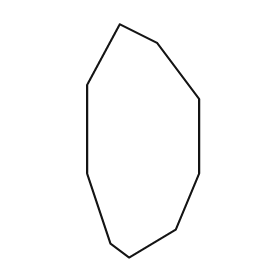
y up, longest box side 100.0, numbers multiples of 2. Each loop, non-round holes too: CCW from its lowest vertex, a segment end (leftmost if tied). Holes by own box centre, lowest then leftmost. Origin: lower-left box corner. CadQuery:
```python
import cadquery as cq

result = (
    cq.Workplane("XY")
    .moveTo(18.0, 0.0)
    .lineTo(38.0, 12.0)
    .lineTo(48.0, 36.0)
    .lineTo(48.0, 68.0)
    .lineTo(30.0, 92.0)
    .lineTo(14.0, 100.0)
    .lineTo(0.0, 74.0)
    .lineTo(0.0, 36.0)
    .lineTo(10.0, 6.0)
    .close()
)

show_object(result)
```